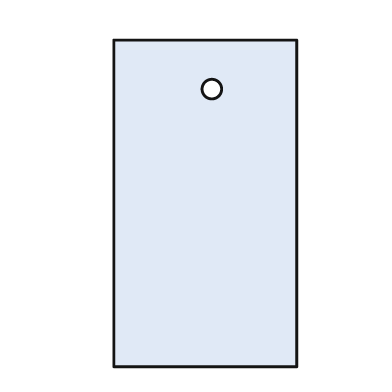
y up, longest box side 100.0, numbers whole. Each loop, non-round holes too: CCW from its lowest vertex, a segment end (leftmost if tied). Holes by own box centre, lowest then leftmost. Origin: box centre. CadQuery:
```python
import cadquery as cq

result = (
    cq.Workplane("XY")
    .moveTo(-28.0, -50.0)
    .lineTo(28.0, -50.0)
    .lineTo(28.0, 50.0)
    .lineTo(-28.0, 50.0)
    .close()
    .moveTo(2.0, 35.0)
    .circle(3.0)
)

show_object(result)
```